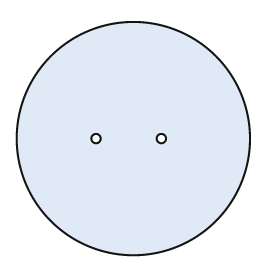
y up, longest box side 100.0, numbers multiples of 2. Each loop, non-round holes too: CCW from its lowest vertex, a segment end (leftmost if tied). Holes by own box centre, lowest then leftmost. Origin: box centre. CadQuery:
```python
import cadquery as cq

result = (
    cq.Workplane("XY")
    .moveTo(0.0, 0.0)
    .circle(50.0)
    .moveTo(-16.0, 0.0)
    .circle(2.0)
    .moveTo(12.0, 0.0)
    .circle(2.0)
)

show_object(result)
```